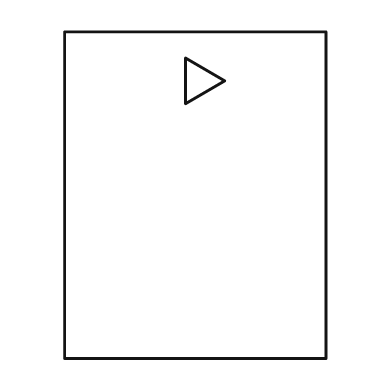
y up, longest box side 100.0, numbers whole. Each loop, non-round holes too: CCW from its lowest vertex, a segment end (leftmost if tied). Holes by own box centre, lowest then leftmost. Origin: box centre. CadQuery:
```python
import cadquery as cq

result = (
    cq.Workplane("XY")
    .moveTo(-40.0, -50.0)
    .lineTo(40.0, -50.0)
    .lineTo(40.0, 50.0)
    .lineTo(-40.0, 50.0)
    .close()
    .moveTo(-3.0, 28.0)
    .lineTo(9.0, 35.0)
    .lineTo(-3.0, 42.0)
    .close()
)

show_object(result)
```